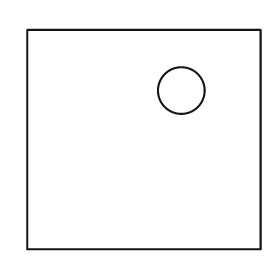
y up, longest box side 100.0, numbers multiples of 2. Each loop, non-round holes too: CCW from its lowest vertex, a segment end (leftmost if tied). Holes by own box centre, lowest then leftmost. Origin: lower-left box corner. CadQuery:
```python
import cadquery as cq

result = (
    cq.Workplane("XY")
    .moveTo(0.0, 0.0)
    .lineTo(100.0, 0.0)
    .lineTo(100.0, 94.0)
    .lineTo(0.0, 94.0)
    .close()
    .moveTo(66.0, 68.0)
    .circle(10.0)
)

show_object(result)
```